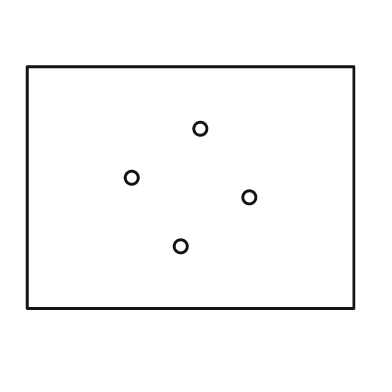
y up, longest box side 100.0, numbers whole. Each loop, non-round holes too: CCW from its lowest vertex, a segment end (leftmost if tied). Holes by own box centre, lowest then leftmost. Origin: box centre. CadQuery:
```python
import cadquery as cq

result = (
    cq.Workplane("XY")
    .moveTo(-50.0, -37.0)
    .lineTo(50.0, -37.0)
    .lineTo(50.0, 37.0)
    .lineTo(-50.0, 37.0)
    .close()
    .moveTo(-3.0, -18.0)
    .circle(2.0)
    .moveTo(18.0, -3.0)
    .circle(2.0)
    .moveTo(-18.0, 3.0)
    .circle(2.0)
    .moveTo(3.0, 18.0)
    .circle(2.0)
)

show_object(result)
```